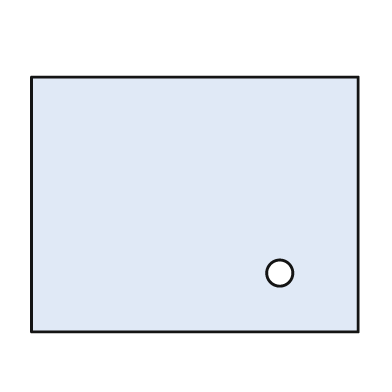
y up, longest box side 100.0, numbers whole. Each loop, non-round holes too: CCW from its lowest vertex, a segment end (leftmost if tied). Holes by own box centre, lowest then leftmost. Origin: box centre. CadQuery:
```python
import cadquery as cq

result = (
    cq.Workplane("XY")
    .moveTo(-50.0, -39.0)
    .lineTo(50.0, -39.0)
    .lineTo(50.0, 39.0)
    .lineTo(-50.0, 39.0)
    .close()
    .moveTo(26.0, -21.0)
    .circle(4.0)
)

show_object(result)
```